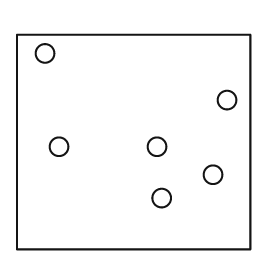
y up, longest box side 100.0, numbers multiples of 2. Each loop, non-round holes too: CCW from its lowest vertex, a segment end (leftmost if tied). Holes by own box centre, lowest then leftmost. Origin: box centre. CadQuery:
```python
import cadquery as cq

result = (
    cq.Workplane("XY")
    .moveTo(-50.0, -46.0)
    .lineTo(50.0, -46.0)
    .lineTo(50.0, 46.0)
    .lineTo(-50.0, 46.0)
    .close()
    .moveTo(12.0, -24.0)
    .circle(4.0)
    .moveTo(34.0, -14.0)
    .circle(4.0)
    .moveTo(-32.0, -2.0)
    .circle(4.0)
    .moveTo(10.0, -2.0)
    .circle(4.0)
    .moveTo(40.0, 18.0)
    .circle(4.0)
    .moveTo(-38.0, 38.0)
    .circle(4.0)
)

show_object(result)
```